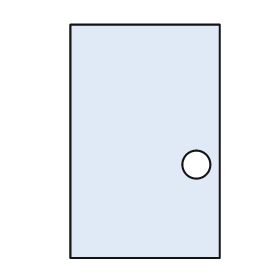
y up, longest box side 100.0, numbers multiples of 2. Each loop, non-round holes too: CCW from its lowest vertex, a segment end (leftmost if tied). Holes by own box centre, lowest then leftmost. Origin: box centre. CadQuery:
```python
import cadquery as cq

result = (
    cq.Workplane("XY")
    .moveTo(-32.0, -50.0)
    .lineTo(32.0, -50.0)
    .lineTo(32.0, 50.0)
    .lineTo(-32.0, 50.0)
    .close()
    .moveTo(22.0, -10.0)
    .circle(6.0)
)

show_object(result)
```